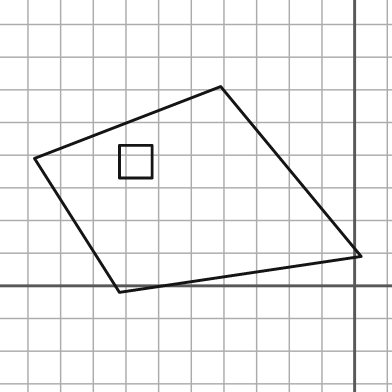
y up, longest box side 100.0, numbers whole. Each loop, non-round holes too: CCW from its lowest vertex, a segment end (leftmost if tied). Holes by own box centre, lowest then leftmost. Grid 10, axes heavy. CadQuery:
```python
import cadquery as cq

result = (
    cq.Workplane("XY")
    .moveTo(-72.0, -2.0)
    .lineTo(2.0, 9.0)
    .lineTo(-41.0, 61.0)
    .lineTo(-98.0, 39.0)
    .close()
    .moveTo(-72.0, 33.0)
    .lineTo(-62.0, 33.0)
    .lineTo(-62.0, 43.0)
    .lineTo(-72.0, 43.0)
    .close()
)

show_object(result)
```